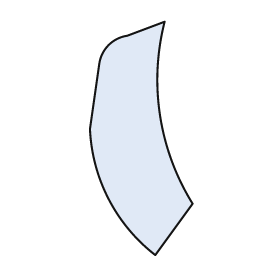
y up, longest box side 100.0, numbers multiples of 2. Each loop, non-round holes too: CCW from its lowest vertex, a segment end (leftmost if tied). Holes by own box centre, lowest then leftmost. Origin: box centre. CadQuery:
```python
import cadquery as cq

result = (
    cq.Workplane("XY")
    .moveTo(6.0, -50.0)
    .lineTo(22.0, -28.0)
    .threePointArc((8.0, 10.0), (10.0, 50.0))
    .lineTo(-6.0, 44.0)
    .threePointArc((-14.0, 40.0), (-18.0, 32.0))
    .lineTo(-22.0, 4.0)
    .threePointArc((-14.0, -26.0), (6.0, -50.0))
    .close()
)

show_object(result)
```